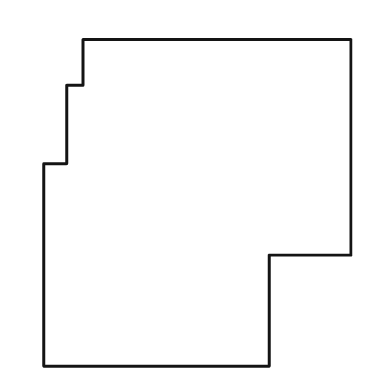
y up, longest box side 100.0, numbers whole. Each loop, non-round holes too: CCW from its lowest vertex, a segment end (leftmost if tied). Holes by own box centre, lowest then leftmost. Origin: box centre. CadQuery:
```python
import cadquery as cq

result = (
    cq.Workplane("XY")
    .moveTo(-47.0, -50.0)
    .lineTo(22.0, -50.0)
    .lineTo(22.0, -16.0)
    .lineTo(47.0, -16.0)
    .lineTo(47.0, 50.0)
    .lineTo(-35.0, 50.0)
    .lineTo(-35.0, 36.0)
    .lineTo(-40.0, 36.0)
    .lineTo(-40.0, 12.0)
    .lineTo(-47.0, 12.0)
    .close()
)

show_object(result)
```